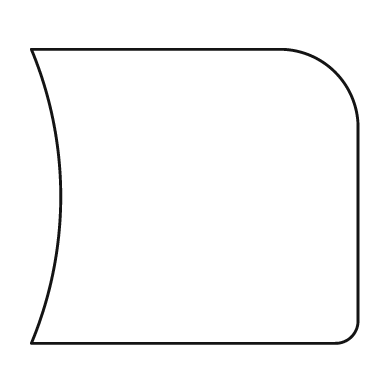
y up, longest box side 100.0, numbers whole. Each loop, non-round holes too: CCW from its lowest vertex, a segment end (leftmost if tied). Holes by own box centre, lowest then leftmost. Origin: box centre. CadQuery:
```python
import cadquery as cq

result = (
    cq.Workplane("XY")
    .moveTo(-50.0, -45.0)
    .lineTo(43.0, -45.0)
    .threePointArc((48.0, -43.0), (50.0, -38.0))
    .lineTo(50.0, 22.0)
    .threePointArc((43.0, 38.0), (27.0, 45.0))
    .lineTo(-50.0, 45.0)
    .threePointArc((-41.0, 0.0), (-50.0, -45.0))
    .close()
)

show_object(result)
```